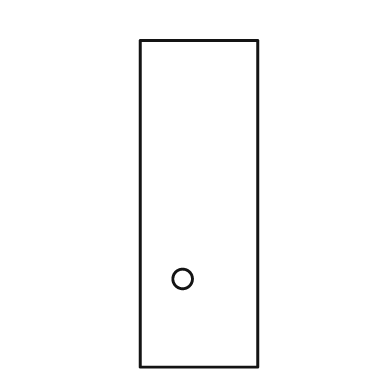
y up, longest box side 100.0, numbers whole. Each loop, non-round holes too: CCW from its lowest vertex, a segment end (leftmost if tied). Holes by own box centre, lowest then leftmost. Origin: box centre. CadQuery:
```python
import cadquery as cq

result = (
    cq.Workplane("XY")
    .moveTo(-18.0, -50.0)
    .lineTo(18.0, -50.0)
    .lineTo(18.0, 50.0)
    .lineTo(-18.0, 50.0)
    .close()
    .moveTo(-5.0, -23.0)
    .circle(3.0)
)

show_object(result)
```